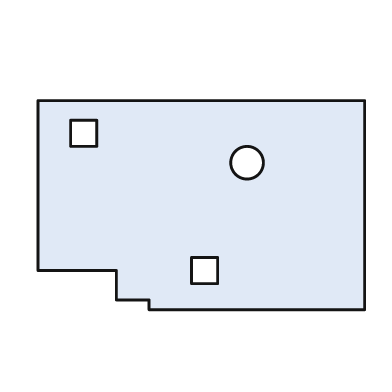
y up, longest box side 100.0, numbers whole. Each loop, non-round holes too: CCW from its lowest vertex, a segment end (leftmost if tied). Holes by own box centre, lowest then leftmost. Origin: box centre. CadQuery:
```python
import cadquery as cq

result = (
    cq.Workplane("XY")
    .moveTo(-16.0, -32.0)
    .lineTo(50.0, -32.0)
    .lineTo(50.0, 32.0)
    .lineTo(-50.0, 32.0)
    .lineTo(-50.0, -20.0)
    .lineTo(-26.0, -20.0)
    .lineTo(-26.0, -29.0)
    .lineTo(-16.0, -29.0)
    .close()
    .moveTo(-3.0, -24.0)
    .lineTo(5.0, -24.0)
    .lineTo(5.0, -16.0)
    .lineTo(-3.0, -16.0)
    .close()
    .moveTo(14.0, 13.0)
    .circle(5.0)
    .moveTo(-40.0, 18.0)
    .lineTo(-32.0, 18.0)
    .lineTo(-32.0, 26.0)
    .lineTo(-40.0, 26.0)
    .close()
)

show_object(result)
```